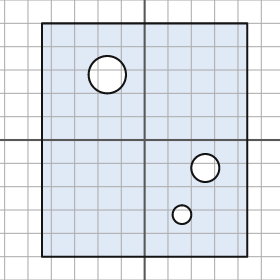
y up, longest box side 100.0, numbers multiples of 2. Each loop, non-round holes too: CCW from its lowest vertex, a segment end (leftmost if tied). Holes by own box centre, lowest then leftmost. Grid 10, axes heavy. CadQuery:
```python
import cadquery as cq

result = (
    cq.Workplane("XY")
    .moveTo(-44.0, -50.0)
    .lineTo(44.0, -50.0)
    .lineTo(44.0, 50.0)
    .lineTo(-44.0, 50.0)
    .close()
    .moveTo(16.0, -32.0)
    .circle(4.0)
    .moveTo(26.0, -12.0)
    .circle(6.0)
    .moveTo(-16.0, 28.0)
    .circle(8.0)
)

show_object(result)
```